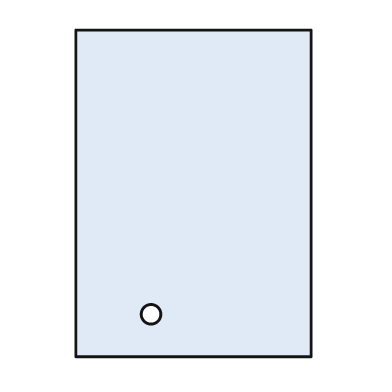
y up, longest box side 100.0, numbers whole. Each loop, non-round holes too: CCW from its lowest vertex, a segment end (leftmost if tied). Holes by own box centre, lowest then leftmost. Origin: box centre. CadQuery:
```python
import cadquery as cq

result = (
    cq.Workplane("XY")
    .moveTo(-36.0, -50.0)
    .lineTo(36.0, -50.0)
    .lineTo(36.0, 50.0)
    .lineTo(-36.0, 50.0)
    .close()
    .moveTo(-13.0, -37.0)
    .circle(3.0)
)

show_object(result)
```